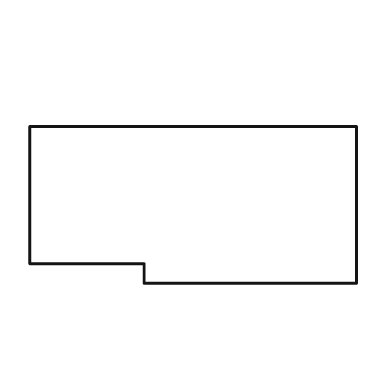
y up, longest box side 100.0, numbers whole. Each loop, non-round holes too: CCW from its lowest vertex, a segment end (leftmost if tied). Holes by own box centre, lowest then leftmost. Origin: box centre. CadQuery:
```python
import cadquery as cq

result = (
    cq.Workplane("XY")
    .moveTo(-15.0, -24.0)
    .lineTo(50.0, -24.0)
    .lineTo(50.0, 24.0)
    .lineTo(-50.0, 24.0)
    .lineTo(-50.0, -18.0)
    .lineTo(-15.0, -18.0)
    .close()
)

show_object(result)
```